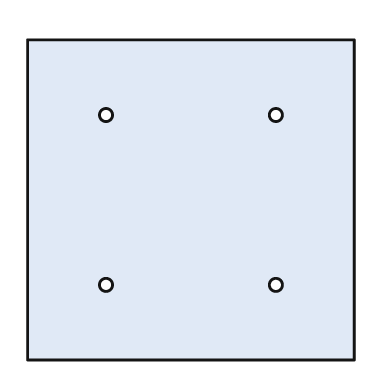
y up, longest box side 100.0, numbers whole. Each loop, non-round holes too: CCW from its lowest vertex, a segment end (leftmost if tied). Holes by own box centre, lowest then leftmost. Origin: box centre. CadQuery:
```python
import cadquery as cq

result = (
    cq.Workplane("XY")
    .moveTo(-50.0, -49.0)
    .lineTo(50.0, -49.0)
    .lineTo(50.0, 49.0)
    .lineTo(-50.0, 49.0)
    .close()
    .moveTo(-26.0, -26.0)
    .circle(2.0)
    .moveTo(26.0, -26.0)
    .circle(2.0)
    .moveTo(-26.0, 26.0)
    .circle(2.0)
    .moveTo(26.0, 26.0)
    .circle(2.0)
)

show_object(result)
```